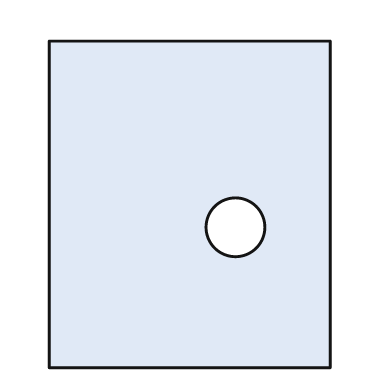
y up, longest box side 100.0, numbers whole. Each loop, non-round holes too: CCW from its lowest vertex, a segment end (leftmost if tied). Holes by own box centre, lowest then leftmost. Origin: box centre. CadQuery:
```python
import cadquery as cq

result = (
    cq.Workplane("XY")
    .moveTo(-43.0, -50.0)
    .lineTo(43.0, -50.0)
    .lineTo(43.0, 50.0)
    .lineTo(-43.0, 50.0)
    .close()
    .moveTo(14.0, -7.0)
    .circle(9.0)
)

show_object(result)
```